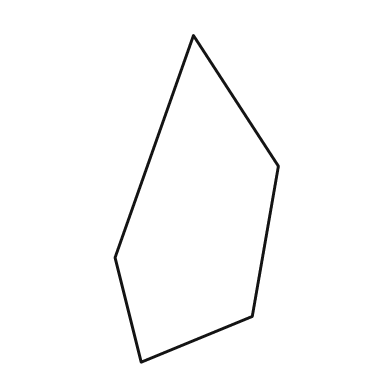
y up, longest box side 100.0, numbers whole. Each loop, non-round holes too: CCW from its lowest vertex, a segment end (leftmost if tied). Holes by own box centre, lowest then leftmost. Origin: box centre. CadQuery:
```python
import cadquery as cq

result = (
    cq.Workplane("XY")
    .moveTo(-17.0, -50.0)
    .lineTo(17.0, -36.0)
    .lineTo(25.0, 10.0)
    .lineTo(-1.0, 50.0)
    .lineTo(-25.0, -18.0)
    .close()
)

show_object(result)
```